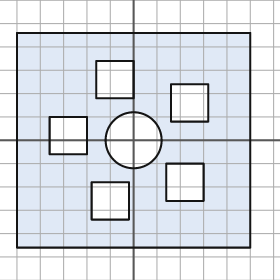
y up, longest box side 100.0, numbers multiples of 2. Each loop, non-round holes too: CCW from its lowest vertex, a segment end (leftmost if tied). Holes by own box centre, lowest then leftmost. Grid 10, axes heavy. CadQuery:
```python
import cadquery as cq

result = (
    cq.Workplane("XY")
    .moveTo(-50.0, -46.0)
    .lineTo(50.0, -46.0)
    .lineTo(50.0, 46.0)
    .lineTo(-50.0, 46.0)
    .close()
    .moveTo(-18.0, -34.0)
    .lineTo(-2.0, -34.0)
    .lineTo(-2.0, -18.0)
    .lineTo(-18.0, -18.0)
    .close()
    .moveTo(14.0, -26.0)
    .lineTo(30.0, -26.0)
    .lineTo(30.0, -10.0)
    .lineTo(14.0, -10.0)
    .close()
    .moveTo(0.0, 0.0)
    .circle(12.0)
    .moveTo(-36.0, -6.0)
    .lineTo(-20.0, -6.0)
    .lineTo(-20.0, 10.0)
    .lineTo(-36.0, 10.0)
    .close()
    .moveTo(16.0, 8.0)
    .lineTo(32.0, 8.0)
    .lineTo(32.0, 24.0)
    .lineTo(16.0, 24.0)
    .close()
    .moveTo(-16.0, 18.0)
    .lineTo(0.0, 18.0)
    .lineTo(0.0, 34.0)
    .lineTo(-16.0, 34.0)
    .close()
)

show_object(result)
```